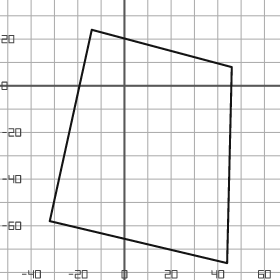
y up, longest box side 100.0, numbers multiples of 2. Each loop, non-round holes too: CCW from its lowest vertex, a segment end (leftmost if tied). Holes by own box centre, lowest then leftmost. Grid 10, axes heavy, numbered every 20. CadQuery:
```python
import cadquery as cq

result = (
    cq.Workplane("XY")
    .moveTo(44.0, -76.0)
    .lineTo(46.0, 8.0)
    .lineTo(-14.0, 24.0)
    .lineTo(-32.0, -58.0)
    .close()
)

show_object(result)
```